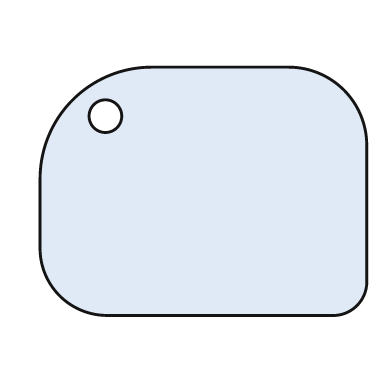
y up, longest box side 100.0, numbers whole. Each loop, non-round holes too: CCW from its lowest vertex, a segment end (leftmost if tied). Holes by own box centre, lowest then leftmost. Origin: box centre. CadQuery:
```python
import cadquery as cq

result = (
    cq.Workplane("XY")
    .moveTo(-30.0, -38.0)
    .lineTo(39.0, -38.0)
    .threePointArc((47.0, -35.0), (50.0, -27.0))
    .lineTo(50.0, 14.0)
    .threePointArc((43.0, 31.0), (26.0, 38.0))
    .lineTo(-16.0, 38.0)
    .threePointArc((-40.0, 28.0), (-50.0, 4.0))
    .lineTo(-50.0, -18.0)
    .threePointArc((-44.0, -32.0), (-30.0, -38.0))
    .close()
    .moveTo(-30.0, 23.0)
    .circle(5.0)
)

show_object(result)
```